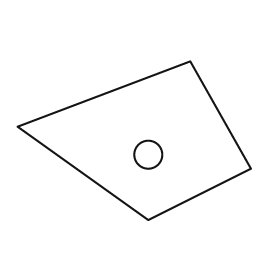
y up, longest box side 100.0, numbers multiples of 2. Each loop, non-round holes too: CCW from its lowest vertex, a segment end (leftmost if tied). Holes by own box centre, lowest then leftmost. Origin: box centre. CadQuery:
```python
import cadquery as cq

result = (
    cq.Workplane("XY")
    .moveTo(6.0, -34.0)
    .lineTo(50.0, -12.0)
    .lineTo(24.0, 34.0)
    .lineTo(-50.0, 6.0)
    .close()
    .moveTo(6.0, -6.0)
    .circle(6.0)
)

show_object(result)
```